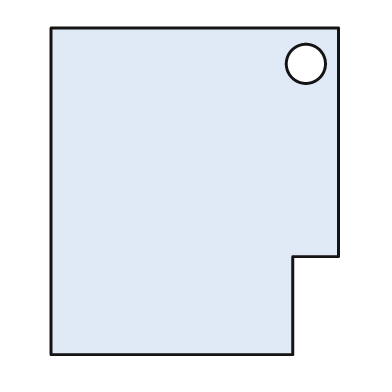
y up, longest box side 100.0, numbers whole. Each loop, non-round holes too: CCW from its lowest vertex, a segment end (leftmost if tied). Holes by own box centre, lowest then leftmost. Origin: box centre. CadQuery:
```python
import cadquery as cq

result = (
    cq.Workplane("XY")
    .moveTo(-44.0, -50.0)
    .lineTo(30.0, -50.0)
    .lineTo(30.0, -20.0)
    .lineTo(44.0, -20.0)
    .lineTo(44.0, 50.0)
    .lineTo(-44.0, 50.0)
    .close()
    .moveTo(34.0, 39.0)
    .circle(6.0)
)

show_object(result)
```